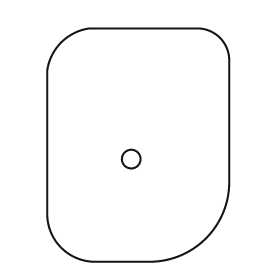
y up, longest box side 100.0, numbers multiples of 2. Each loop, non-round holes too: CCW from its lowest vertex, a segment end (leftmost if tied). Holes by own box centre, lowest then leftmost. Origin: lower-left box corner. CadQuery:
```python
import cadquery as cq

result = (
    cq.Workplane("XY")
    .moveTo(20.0, 0.0)
    .lineTo(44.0, 0.0)
    .threePointArc((68.0, 10.0), (78.0, 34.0))
    .lineTo(78.0, 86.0)
    .threePointArc((74.0, 96.0), (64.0, 100.0))
    .lineTo(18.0, 100.0)
    .threePointArc((6.0, 94.0), (0.0, 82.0))
    .lineTo(0.0, 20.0)
    .threePointArc((6.0, 6.0), (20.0, 0.0))
    .close()
    .moveTo(36.0, 44.0)
    .circle(4.0)
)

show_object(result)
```